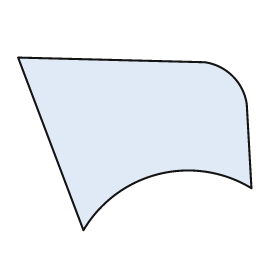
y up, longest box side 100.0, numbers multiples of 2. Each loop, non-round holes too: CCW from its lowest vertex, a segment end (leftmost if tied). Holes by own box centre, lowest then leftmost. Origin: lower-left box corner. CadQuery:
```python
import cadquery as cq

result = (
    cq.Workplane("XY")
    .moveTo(28.0, 0.0)
    .threePointArc((60.0, 24.0), (100.0, 18.0))
    .lineTo(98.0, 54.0)
    .threePointArc((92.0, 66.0), (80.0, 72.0))
    .lineTo(0.0, 74.0)
    .close()
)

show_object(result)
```